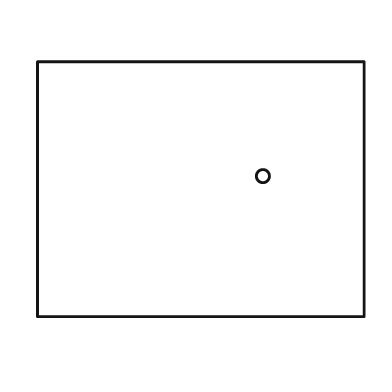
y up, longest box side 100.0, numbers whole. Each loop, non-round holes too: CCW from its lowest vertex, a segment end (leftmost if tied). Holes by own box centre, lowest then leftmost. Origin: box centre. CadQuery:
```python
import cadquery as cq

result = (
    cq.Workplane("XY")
    .moveTo(-50.0, -39.0)
    .lineTo(50.0, -39.0)
    .lineTo(50.0, 39.0)
    .lineTo(-50.0, 39.0)
    .close()
    .moveTo(19.0, 4.0)
    .circle(2.0)
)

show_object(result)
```